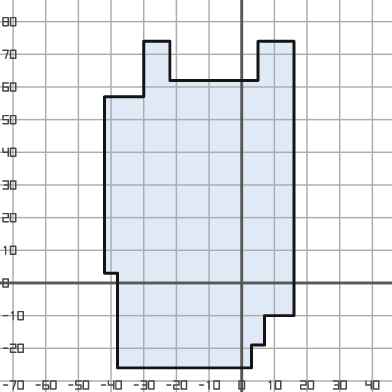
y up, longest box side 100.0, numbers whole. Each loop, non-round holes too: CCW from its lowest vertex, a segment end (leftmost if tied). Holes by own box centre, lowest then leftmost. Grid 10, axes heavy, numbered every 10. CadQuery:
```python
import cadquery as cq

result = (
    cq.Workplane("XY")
    .moveTo(-38.0, -26.0)
    .lineTo(3.0, -26.0)
    .lineTo(3.0, -19.0)
    .lineTo(7.0, -19.0)
    .lineTo(7.0, -10.0)
    .lineTo(16.0, -10.0)
    .lineTo(16.0, 74.0)
    .lineTo(5.0, 74.0)
    .lineTo(5.0, 62.0)
    .lineTo(-22.0, 62.0)
    .lineTo(-22.0, 74.0)
    .lineTo(-30.0, 74.0)
    .lineTo(-30.0, 57.0)
    .lineTo(-42.0, 57.0)
    .lineTo(-42.0, 3.0)
    .lineTo(-38.0, 3.0)
    .close()
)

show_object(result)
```